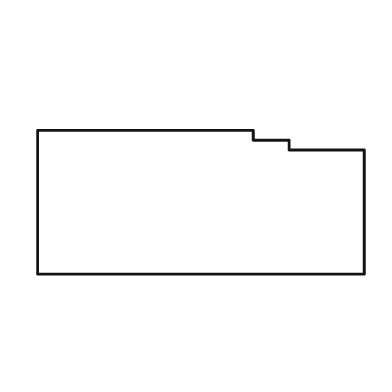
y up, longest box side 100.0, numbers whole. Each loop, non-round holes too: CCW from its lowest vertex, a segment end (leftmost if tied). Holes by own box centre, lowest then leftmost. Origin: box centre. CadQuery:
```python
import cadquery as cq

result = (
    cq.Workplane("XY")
    .moveTo(-50.0, -22.0)
    .lineTo(50.0, -22.0)
    .lineTo(50.0, 16.0)
    .lineTo(27.0, 16.0)
    .lineTo(27.0, 19.0)
    .lineTo(16.0, 19.0)
    .lineTo(16.0, 22.0)
    .lineTo(-50.0, 22.0)
    .close()
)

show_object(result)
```